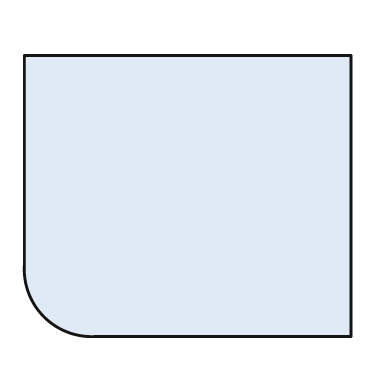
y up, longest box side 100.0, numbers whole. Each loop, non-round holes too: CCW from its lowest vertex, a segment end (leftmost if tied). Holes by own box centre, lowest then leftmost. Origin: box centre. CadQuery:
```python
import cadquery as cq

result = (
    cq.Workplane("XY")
    .moveTo(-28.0, -43.0)
    .lineTo(50.0, -43.0)
    .lineTo(50.0, 43.0)
    .lineTo(-50.0, 43.0)
    .lineTo(-50.0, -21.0)
    .threePointArc((-44.0, -37.0), (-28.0, -43.0))
    .close()
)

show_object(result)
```